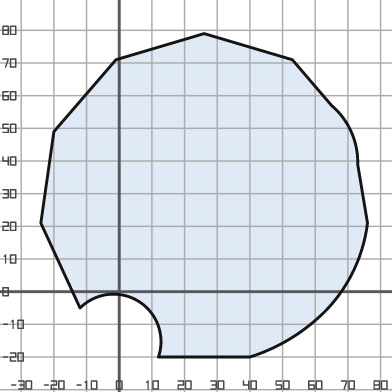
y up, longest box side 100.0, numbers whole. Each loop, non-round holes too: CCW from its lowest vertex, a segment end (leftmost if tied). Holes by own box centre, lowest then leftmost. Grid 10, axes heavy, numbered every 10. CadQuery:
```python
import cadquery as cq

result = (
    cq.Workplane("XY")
    .moveTo(12.0, -20.0)
    .lineTo(40.0, -20.0)
    .threePointArc((53.0, -14.0), (64.0, -5.0))
    .threePointArc((72.0, 7.0), (76.0, 21.0))
    .lineTo(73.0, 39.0)
    .threePointArc((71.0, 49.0), (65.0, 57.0))
    .lineTo(53.0, 71.0)
    .lineTo(26.0, 79.0)
    .lineTo(-1.0, 71.0)
    .lineTo(-20.0, 49.0)
    .lineTo(-24.0, 21.0)
    .lineTo(-12.0, -5.0)
    .threePointArc((6.0, -3.0), (12.0, -20.0))
    .close()
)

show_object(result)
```